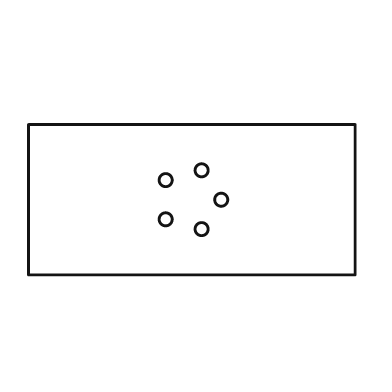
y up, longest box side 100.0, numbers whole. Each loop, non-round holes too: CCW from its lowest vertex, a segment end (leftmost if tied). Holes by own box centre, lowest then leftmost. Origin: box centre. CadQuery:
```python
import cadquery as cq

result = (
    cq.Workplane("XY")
    .moveTo(-50.0, -23.0)
    .lineTo(50.0, -23.0)
    .lineTo(50.0, 23.0)
    .lineTo(-50.0, 23.0)
    .close()
    .moveTo(3.0, -9.0)
    .circle(2.0)
    .moveTo(-8.0, -6.0)
    .circle(2.0)
    .moveTo(9.0, 0.0)
    .circle(2.0)
    .moveTo(-8.0, 6.0)
    .circle(2.0)
    .moveTo(3.0, 9.0)
    .circle(2.0)
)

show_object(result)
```